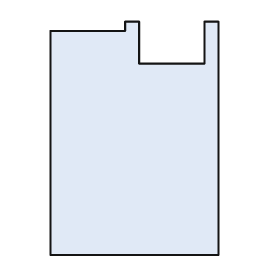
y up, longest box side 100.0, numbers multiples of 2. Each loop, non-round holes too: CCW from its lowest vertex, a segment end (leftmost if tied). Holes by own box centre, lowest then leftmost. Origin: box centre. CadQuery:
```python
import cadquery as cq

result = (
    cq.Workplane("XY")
    .moveTo(-36.0, -50.0)
    .lineTo(36.0, -50.0)
    .lineTo(36.0, 50.0)
    .lineTo(30.0, 50.0)
    .lineTo(30.0, 32.0)
    .lineTo(2.0, 32.0)
    .lineTo(2.0, 50.0)
    .lineTo(-4.0, 50.0)
    .lineTo(-4.0, 46.0)
    .lineTo(-36.0, 46.0)
    .close()
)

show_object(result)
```